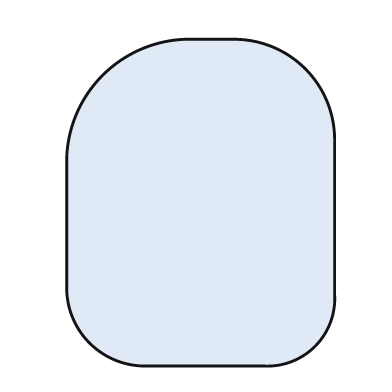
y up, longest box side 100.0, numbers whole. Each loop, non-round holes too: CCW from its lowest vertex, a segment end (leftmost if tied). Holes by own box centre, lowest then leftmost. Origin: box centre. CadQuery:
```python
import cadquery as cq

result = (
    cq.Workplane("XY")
    .moveTo(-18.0, -50.0)
    .lineTo(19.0, -50.0)
    .threePointArc((35.0, -44.0), (41.0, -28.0))
    .lineTo(41.0, 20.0)
    .threePointArc((32.0, 41.0), (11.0, 50.0))
    .lineTo(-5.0, 50.0)
    .threePointArc((-30.0, 39.0), (-41.0, 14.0))
    .lineTo(-41.0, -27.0)
    .threePointArc((-34.0, -43.0), (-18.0, -50.0))
    .close()
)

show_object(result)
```